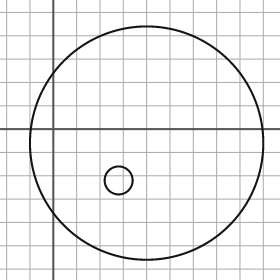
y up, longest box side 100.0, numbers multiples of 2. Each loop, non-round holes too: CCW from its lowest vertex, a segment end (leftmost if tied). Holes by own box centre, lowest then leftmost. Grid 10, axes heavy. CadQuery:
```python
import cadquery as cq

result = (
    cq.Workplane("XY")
    .moveTo(40.0, -6.0)
    .circle(50.0)
    .moveTo(28.0, -22.0)
    .circle(6.0)
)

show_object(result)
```